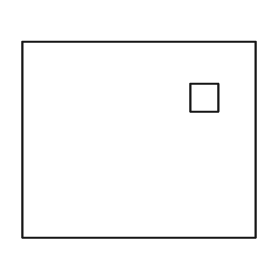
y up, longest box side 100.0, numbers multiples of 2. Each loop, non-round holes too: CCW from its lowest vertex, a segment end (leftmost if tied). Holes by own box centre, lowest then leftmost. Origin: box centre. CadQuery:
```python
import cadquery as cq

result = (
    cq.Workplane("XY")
    .moveTo(-50.0, -42.0)
    .lineTo(50.0, -42.0)
    .lineTo(50.0, 42.0)
    .lineTo(-50.0, 42.0)
    .close()
    .moveTo(22.0, 12.0)
    .lineTo(34.0, 12.0)
    .lineTo(34.0, 24.0)
    .lineTo(22.0, 24.0)
    .close()
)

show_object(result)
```